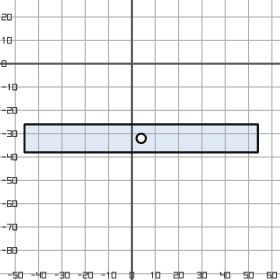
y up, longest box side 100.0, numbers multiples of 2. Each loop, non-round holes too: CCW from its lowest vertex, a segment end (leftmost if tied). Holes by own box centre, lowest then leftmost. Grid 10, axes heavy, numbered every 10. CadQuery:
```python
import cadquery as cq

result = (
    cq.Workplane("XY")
    .moveTo(-46.0, -38.0)
    .lineTo(54.0, -38.0)
    .lineTo(54.0, -26.0)
    .lineTo(-46.0, -26.0)
    .close()
    .moveTo(4.0, -32.0)
    .circle(2.0)
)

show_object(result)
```